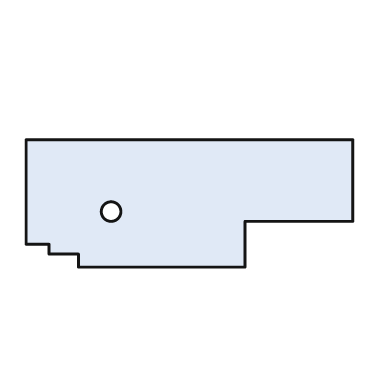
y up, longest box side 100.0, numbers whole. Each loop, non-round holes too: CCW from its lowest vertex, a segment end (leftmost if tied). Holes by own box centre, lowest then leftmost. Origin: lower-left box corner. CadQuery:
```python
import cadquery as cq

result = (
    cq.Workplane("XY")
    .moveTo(16.0, 0.0)
    .lineTo(67.0, 0.0)
    .lineTo(67.0, 14.0)
    .lineTo(100.0, 14.0)
    .lineTo(100.0, 39.0)
    .lineTo(0.0, 39.0)
    .lineTo(0.0, 7.0)
    .lineTo(7.0, 7.0)
    .lineTo(7.0, 4.0)
    .lineTo(16.0, 4.0)
    .close()
    .moveTo(26.0, 17.0)
    .circle(3.0)
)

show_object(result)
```